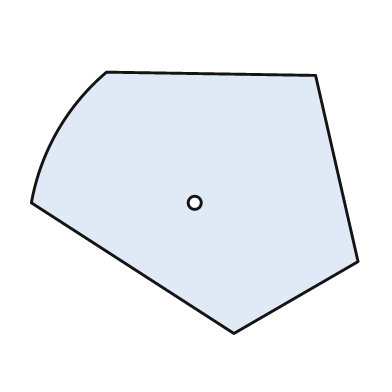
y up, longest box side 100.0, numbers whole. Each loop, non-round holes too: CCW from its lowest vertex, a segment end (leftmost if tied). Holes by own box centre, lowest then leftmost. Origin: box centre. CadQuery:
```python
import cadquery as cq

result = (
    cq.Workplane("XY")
    .moveTo(12.0, -40.0)
    .lineTo(50.0, -18.0)
    .lineTo(37.0, 39.0)
    .lineTo(-27.0, 40.0)
    .threePointArc((-42.0, 22.0), (-50.0, 0.0))
    .close()
    .moveTo(0.0, 0.0)
    .circle(2.0)
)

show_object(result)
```